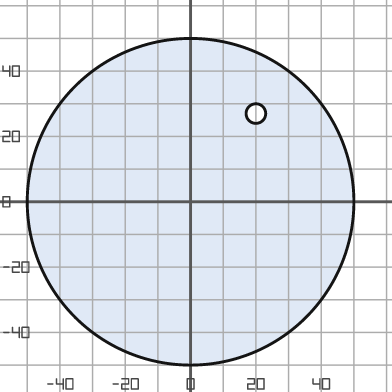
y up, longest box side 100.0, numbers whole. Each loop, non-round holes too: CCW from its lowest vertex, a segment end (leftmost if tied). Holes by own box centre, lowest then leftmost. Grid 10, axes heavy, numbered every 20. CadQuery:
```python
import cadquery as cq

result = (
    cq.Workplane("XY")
    .moveTo(0.0, 0.0)
    .circle(50.0)
    .moveTo(20.0, 27.0)
    .circle(3.0)
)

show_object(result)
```